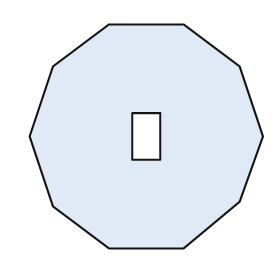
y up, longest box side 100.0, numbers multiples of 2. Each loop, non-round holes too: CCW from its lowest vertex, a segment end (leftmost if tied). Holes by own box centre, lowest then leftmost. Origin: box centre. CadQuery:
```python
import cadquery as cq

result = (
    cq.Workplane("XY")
    .moveTo(-16.0, -48.0)
    .lineTo(16.0, -48.0)
    .lineTo(40.0, -28.0)
    .lineTo(50.0, 0.0)
    .lineTo(40.0, 30.0)
    .lineTo(16.0, 48.0)
    .lineTo(-16.0, 48.0)
    .lineTo(-40.0, 30.0)
    .lineTo(-50.0, 0.0)
    .lineTo(-40.0, -30.0)
    .close()
    .moveTo(-6.0, -10.0)
    .lineTo(6.0, -10.0)
    .lineTo(6.0, 10.0)
    .lineTo(-6.0, 10.0)
    .close()
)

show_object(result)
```